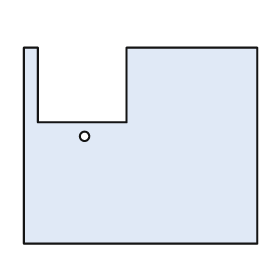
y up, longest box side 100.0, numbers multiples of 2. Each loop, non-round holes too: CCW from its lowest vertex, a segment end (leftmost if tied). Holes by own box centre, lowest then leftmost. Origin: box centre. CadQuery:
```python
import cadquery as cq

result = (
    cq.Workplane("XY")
    .moveTo(-50.0, -42.0)
    .lineTo(50.0, -42.0)
    .lineTo(50.0, 42.0)
    .lineTo(-6.0, 42.0)
    .lineTo(-6.0, 10.0)
    .lineTo(-44.0, 10.0)
    .lineTo(-44.0, 42.0)
    .lineTo(-50.0, 42.0)
    .close()
    .moveTo(-24.0, 4.0)
    .circle(2.0)
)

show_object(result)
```